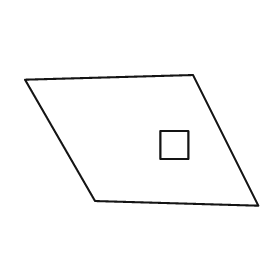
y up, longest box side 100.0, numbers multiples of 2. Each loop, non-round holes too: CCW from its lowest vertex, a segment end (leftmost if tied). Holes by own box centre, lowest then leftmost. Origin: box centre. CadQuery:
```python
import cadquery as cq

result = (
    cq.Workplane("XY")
    .moveTo(50.0, -28.0)
    .lineTo(22.0, 28.0)
    .lineTo(-50.0, 26.0)
    .lineTo(-20.0, -26.0)
    .close()
    .moveTo(8.0, -8.0)
    .lineTo(20.0, -8.0)
    .lineTo(20.0, 4.0)
    .lineTo(8.0, 4.0)
    .close()
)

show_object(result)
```